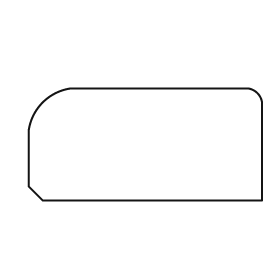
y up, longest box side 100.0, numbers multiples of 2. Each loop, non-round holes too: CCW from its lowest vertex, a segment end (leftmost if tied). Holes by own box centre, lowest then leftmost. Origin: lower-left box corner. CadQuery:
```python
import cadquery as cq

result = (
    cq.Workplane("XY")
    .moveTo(6.0, 0.0)
    .lineTo(100.0, 0.0)
    .lineTo(100.0, 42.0)
    .threePointArc((98.0, 46.0), (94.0, 48.0))
    .lineTo(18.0, 48.0)
    .threePointArc((6.0, 42.0), (0.0, 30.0))
    .lineTo(0.0, 6.0)
    .close()
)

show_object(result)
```